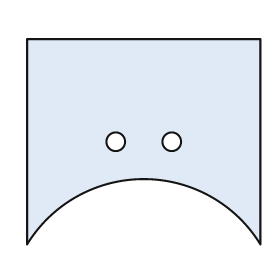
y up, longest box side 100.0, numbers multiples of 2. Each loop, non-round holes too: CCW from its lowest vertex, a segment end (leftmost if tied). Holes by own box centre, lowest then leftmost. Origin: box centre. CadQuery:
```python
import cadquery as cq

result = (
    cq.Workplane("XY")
    .moveTo(-50.0, -44.0)
    .threePointArc((0.0, -16.0), (50.0, -44.0))
    .lineTo(50.0, 44.0)
    .lineTo(-50.0, 44.0)
    .close()
    .moveTo(-12.0, 0.0)
    .circle(4.0)
    .moveTo(12.0, 0.0)
    .circle(4.0)
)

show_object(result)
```